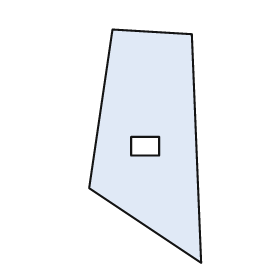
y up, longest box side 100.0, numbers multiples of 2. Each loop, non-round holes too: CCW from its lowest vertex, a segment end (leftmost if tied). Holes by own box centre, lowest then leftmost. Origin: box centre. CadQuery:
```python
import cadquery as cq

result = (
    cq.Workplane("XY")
    .moveTo(24.0, -50.0)
    .lineTo(20.0, 48.0)
    .lineTo(-14.0, 50.0)
    .lineTo(-24.0, -18.0)
    .close()
    .moveTo(-6.0, -4.0)
    .lineTo(6.0, -4.0)
    .lineTo(6.0, 4.0)
    .lineTo(-6.0, 4.0)
    .close()
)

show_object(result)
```